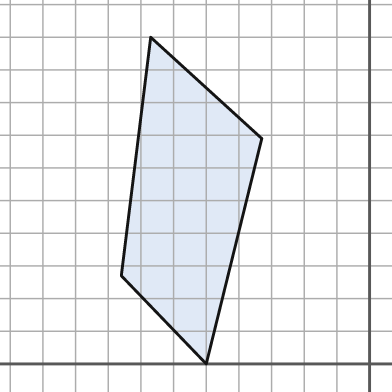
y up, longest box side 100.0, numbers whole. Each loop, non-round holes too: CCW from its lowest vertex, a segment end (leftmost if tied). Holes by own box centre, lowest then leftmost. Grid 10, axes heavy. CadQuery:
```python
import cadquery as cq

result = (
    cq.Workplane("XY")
    .moveTo(-50.0, 0.0)
    .lineTo(-33.0, 69.0)
    .lineTo(-67.0, 100.0)
    .lineTo(-76.0, 27.0)
    .close()
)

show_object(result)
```